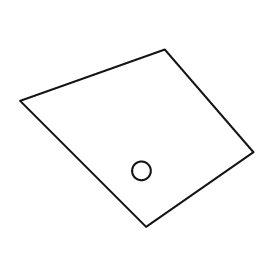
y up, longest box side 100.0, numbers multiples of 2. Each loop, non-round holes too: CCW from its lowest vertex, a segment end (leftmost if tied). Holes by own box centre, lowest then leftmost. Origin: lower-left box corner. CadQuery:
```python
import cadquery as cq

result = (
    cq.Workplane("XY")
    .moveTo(54.0, 0.0)
    .lineTo(100.0, 32.0)
    .lineTo(62.0, 76.0)
    .lineTo(0.0, 54.0)
    .close()
    .moveTo(52.0, 24.0)
    .circle(4.0)
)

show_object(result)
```